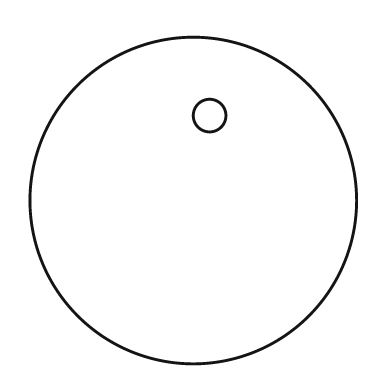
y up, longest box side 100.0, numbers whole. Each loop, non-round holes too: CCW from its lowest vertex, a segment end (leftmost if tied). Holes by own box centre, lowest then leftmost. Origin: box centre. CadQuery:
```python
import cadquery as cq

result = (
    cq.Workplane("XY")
    .moveTo(0.0, 0.0)
    .circle(50.0)
    .moveTo(5.0, 26.0)
    .circle(5.0)
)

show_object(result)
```